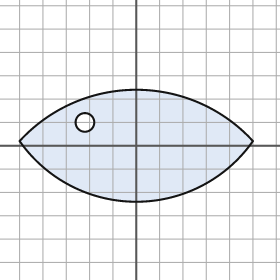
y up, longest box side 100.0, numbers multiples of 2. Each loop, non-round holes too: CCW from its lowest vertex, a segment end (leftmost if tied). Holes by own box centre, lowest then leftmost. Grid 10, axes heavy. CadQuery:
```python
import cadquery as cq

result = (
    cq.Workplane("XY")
    .moveTo(-50.0, 2.0)
    .threePointArc((0.0, -24.0), (50.0, 2.0))
    .threePointArc((0.0, 24.0), (-50.0, 2.0))
    .close()
    .moveTo(-22.0, 10.0)
    .circle(4.0)
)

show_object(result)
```